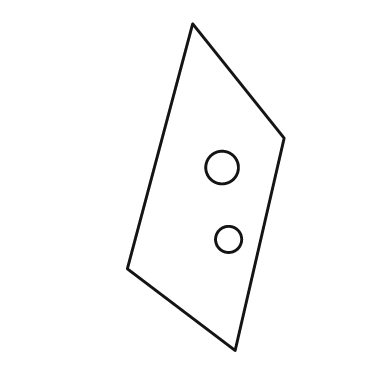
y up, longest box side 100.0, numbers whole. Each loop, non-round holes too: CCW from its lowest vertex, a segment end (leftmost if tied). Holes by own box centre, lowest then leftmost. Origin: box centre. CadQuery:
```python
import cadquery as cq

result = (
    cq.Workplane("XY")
    .moveTo(9.0, -50.0)
    .lineTo(24.0, 15.0)
    .lineTo(-4.0, 50.0)
    .lineTo(-24.0, -25.0)
    .close()
    .moveTo(7.0, -16.0)
    .circle(4.0)
    .moveTo(5.0, 6.0)
    .circle(5.0)
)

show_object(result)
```